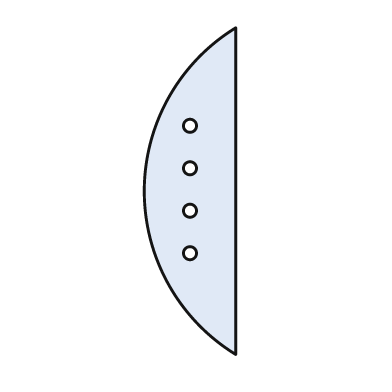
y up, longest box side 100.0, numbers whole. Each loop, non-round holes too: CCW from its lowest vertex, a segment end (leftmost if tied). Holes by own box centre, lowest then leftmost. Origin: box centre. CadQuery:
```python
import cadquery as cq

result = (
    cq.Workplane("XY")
    .moveTo(14.0, -50.0)
    .lineTo(14.0, 50.0)
    .threePointArc((-14.0, 0.0), (14.0, -50.0))
    .close()
    .moveTo(0.0, -19.0)
    .circle(2.0)
    .moveTo(0.0, -6.0)
    .circle(2.0)
    .moveTo(0.0, 7.0)
    .circle(2.0)
    .moveTo(0.0, 20.0)
    .circle(2.0)
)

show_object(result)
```